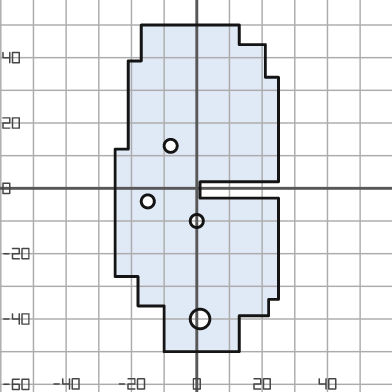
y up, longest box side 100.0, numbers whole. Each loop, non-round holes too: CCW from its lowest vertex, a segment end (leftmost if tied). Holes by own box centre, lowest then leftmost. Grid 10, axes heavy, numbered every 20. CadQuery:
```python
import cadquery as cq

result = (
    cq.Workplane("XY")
    .moveTo(-10.0, -50.0)
    .lineTo(13.0, -50.0)
    .lineTo(13.0, -39.0)
    .lineTo(22.0, -39.0)
    .lineTo(22.0, -34.0)
    .lineTo(25.0, -34.0)
    .lineTo(25.0, -3.0)
    .lineTo(1.0, -3.0)
    .lineTo(1.0, 2.0)
    .lineTo(25.0, 2.0)
    .lineTo(25.0, 34.0)
    .lineTo(21.0, 34.0)
    .lineTo(21.0, 44.0)
    .lineTo(13.0, 44.0)
    .lineTo(13.0, 50.0)
    .lineTo(-17.0, 50.0)
    .lineTo(-17.0, 39.0)
    .lineTo(-21.0, 39.0)
    .lineTo(-21.0, 12.0)
    .lineTo(-25.0, 12.0)
    .lineTo(-25.0, -27.0)
    .lineTo(-18.0, -27.0)
    .lineTo(-18.0, -36.0)
    .lineTo(-10.0, -36.0)
    .close()
    .moveTo(1.0, -40.0)
    .circle(3.0)
    .moveTo(0.0, -10.0)
    .circle(2.0)
    .moveTo(-15.0, -4.0)
    .circle(2.0)
    .moveTo(-8.0, 13.0)
    .circle(2.0)
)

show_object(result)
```